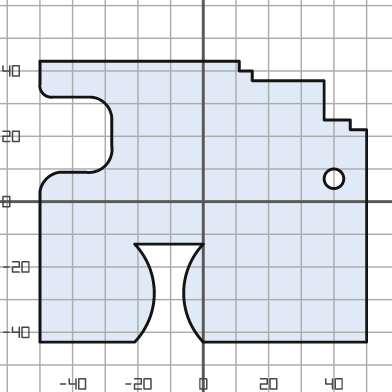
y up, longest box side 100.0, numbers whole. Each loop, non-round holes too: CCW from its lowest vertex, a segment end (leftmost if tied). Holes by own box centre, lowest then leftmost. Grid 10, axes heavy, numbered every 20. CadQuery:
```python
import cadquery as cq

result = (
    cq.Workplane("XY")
    .moveTo(-50.0, -43.0)
    .lineTo(-21.0, -43.0)
    .threePointArc((-15.0, -28.0), (-21.0, -13.0))
    .lineTo(0.0, -13.0)
    .threePointArc((-6.0, -28.0), (0.0, -43.0))
    .lineTo(50.0, -43.0)
    .lineTo(50.0, 22.0)
    .lineTo(45.0, 22.0)
    .lineTo(45.0, 25.0)
    .lineTo(37.0, 25.0)
    .lineTo(37.0, 37.0)
    .lineTo(15.0, 37.0)
    .lineTo(15.0, 40.0)
    .lineTo(11.0, 40.0)
    .lineTo(11.0, 43.0)
    .lineTo(-50.0, 43.0)
    .lineTo(-50.0, 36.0)
    .threePointArc((-49.0, 33.0), (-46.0, 32.0))
    .lineTo(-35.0, 32.0)
    .threePointArc((-30.0, 30.0), (-28.0, 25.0))
    .lineTo(-28.0, 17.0)
    .threePointArc((-30.0, 11.0), (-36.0, 9.0))
    .lineTo(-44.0, 9.0)
    .threePointArc((-48.0, 7.0), (-50.0, 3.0))
    .close()
    .moveTo(40.0, 7.0)
    .circle(3.0)
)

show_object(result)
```